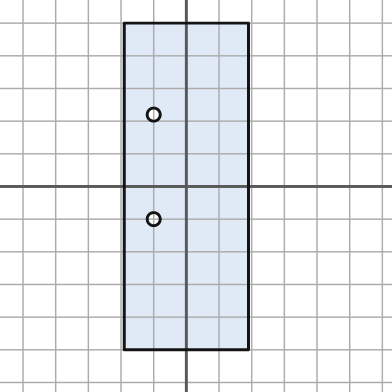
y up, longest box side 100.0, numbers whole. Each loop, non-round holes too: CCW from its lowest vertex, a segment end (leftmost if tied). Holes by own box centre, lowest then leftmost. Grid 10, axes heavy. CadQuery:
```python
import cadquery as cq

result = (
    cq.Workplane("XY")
    .moveTo(-19.0, -50.0)
    .lineTo(19.0, -50.0)
    .lineTo(19.0, 50.0)
    .lineTo(-19.0, 50.0)
    .close()
    .moveTo(-10.0, -10.0)
    .circle(2.0)
    .moveTo(-10.0, 22.0)
    .circle(2.0)
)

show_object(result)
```